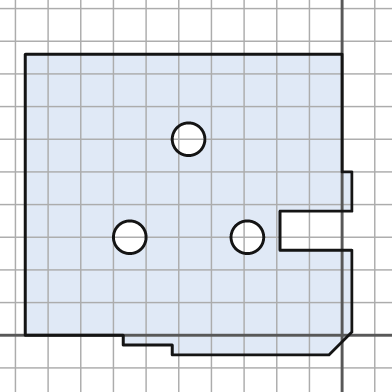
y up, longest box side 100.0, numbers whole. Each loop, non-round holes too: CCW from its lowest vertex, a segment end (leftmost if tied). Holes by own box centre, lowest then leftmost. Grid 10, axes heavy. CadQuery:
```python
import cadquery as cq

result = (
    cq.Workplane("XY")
    .moveTo(-52.0, -6.0)
    .lineTo(-4.0, -6.0)
    .lineTo(3.0, 1.0)
    .lineTo(3.0, 26.0)
    .lineTo(-19.0, 26.0)
    .lineTo(-19.0, 38.0)
    .lineTo(3.0, 38.0)
    .lineTo(3.0, 50.0)
    .lineTo(0.0, 50.0)
    .lineTo(0.0, 86.0)
    .lineTo(-97.0, 86.0)
    .lineTo(-97.0, 0.0)
    .lineTo(-67.0, 0.0)
    .lineTo(-67.0, -3.0)
    .lineTo(-52.0, -3.0)
    .close()
    .moveTo(-65.0, 30.0)
    .circle(5.0)
    .moveTo(-29.0, 30.0)
    .circle(5.0)
    .moveTo(-47.0, 60.0)
    .circle(5.0)
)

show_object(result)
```